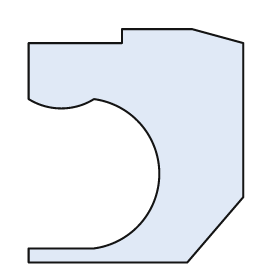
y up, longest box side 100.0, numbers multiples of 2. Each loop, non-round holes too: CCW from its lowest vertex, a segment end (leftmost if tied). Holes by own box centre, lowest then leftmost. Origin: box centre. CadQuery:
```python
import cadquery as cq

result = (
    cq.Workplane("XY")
    .moveTo(-46.0, -50.0)
    .lineTo(22.0, -50.0)
    .lineTo(46.0, -22.0)
    .lineTo(46.0, 44.0)
    .lineTo(24.0, 50.0)
    .lineTo(-6.0, 50.0)
    .lineTo(-6.0, 44.0)
    .lineTo(-46.0, 44.0)
    .lineTo(-46.0, 20.0)
    .threePointArc((-32.0, 16.0), (-18.0, 20.0))
    .threePointArc((10.0, -12.0), (-18.0, -44.0))
    .lineTo(-46.0, -44.0)
    .close()
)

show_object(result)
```